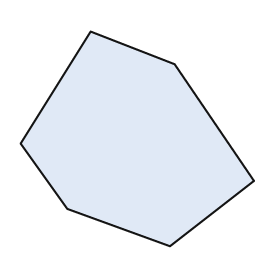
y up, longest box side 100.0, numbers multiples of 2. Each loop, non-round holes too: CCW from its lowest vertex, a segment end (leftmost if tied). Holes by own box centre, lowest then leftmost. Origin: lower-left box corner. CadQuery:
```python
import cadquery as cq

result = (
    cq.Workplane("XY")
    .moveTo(64.0, 0.0)
    .lineTo(100.0, 28.0)
    .lineTo(66.0, 78.0)
    .lineTo(30.0, 92.0)
    .lineTo(0.0, 44.0)
    .lineTo(20.0, 16.0)
    .close()
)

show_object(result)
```